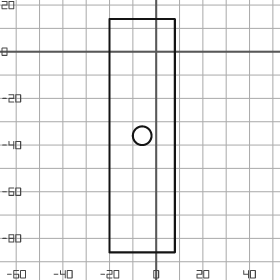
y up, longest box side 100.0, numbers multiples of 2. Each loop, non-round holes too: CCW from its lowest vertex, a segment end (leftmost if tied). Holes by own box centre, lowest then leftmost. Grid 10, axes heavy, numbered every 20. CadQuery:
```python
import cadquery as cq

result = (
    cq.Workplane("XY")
    .moveTo(-20.0, -86.0)
    .lineTo(8.0, -86.0)
    .lineTo(8.0, 14.0)
    .lineTo(-20.0, 14.0)
    .close()
    .moveTo(-6.0, -36.0)
    .circle(4.0)
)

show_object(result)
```